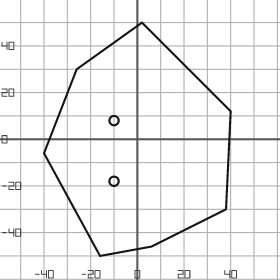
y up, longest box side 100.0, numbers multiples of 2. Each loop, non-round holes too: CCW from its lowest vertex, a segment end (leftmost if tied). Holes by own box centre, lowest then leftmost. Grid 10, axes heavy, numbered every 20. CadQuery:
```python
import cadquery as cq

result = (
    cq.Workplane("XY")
    .moveTo(-16.0, -50.0)
    .lineTo(6.0, -46.0)
    .lineTo(38.0, -30.0)
    .lineTo(40.0, 12.0)
    .lineTo(2.0, 50.0)
    .lineTo(-26.0, 30.0)
    .lineTo(-40.0, -6.0)
    .close()
    .moveTo(-10.0, -18.0)
    .circle(2.0)
    .moveTo(-10.0, 8.0)
    .circle(2.0)
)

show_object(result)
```